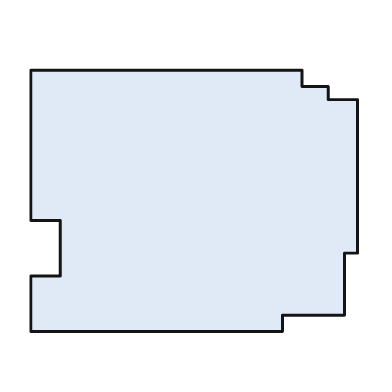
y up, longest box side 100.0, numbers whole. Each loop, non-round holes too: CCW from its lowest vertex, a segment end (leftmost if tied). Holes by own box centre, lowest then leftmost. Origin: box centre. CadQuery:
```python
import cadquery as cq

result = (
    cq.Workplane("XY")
    .moveTo(-50.0, -40.0)
    .lineTo(27.0, -40.0)
    .lineTo(27.0, -35.0)
    .lineTo(46.0, -35.0)
    .lineTo(46.0, -16.0)
    .lineTo(50.0, -16.0)
    .lineTo(50.0, 31.0)
    .lineTo(41.0, 31.0)
    .lineTo(41.0, 35.0)
    .lineTo(33.0, 35.0)
    .lineTo(33.0, 40.0)
    .lineTo(-50.0, 40.0)
    .lineTo(-50.0, -6.0)
    .lineTo(-41.0, -6.0)
    .lineTo(-41.0, -23.0)
    .lineTo(-50.0, -23.0)
    .close()
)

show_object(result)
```